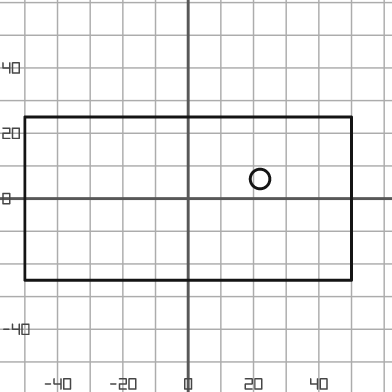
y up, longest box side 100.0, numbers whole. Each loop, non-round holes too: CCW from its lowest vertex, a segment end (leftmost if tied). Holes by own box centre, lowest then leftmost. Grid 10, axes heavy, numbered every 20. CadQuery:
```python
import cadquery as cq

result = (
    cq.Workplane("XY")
    .moveTo(-50.0, -25.0)
    .lineTo(50.0, -25.0)
    .lineTo(50.0, 25.0)
    .lineTo(-50.0, 25.0)
    .close()
    .moveTo(22.0, 6.0)
    .circle(3.0)
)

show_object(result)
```